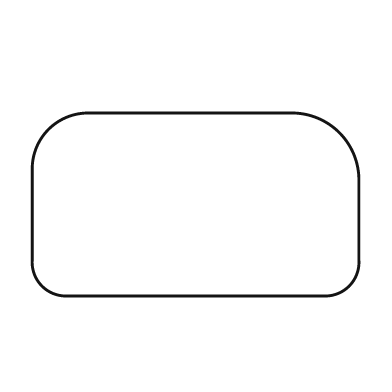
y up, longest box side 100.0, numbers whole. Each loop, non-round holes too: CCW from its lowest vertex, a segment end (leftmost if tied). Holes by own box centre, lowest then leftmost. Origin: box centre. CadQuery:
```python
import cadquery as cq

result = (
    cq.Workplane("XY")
    .moveTo(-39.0, -28.0)
    .lineTo(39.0, -28.0)
    .threePointArc((47.0, -25.0), (50.0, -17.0))
    .lineTo(50.0, 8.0)
    .threePointArc((44.0, 22.0), (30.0, 28.0))
    .lineTo(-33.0, 28.0)
    .threePointArc((-45.0, 23.0), (-50.0, 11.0))
    .lineTo(-50.0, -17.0)
    .threePointArc((-47.0, -25.0), (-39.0, -28.0))
    .close()
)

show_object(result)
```